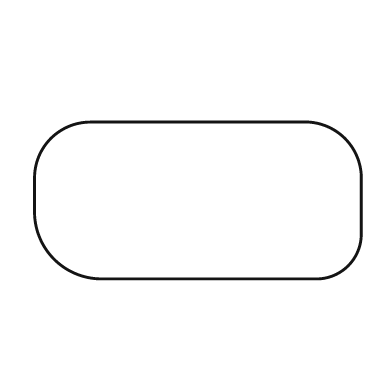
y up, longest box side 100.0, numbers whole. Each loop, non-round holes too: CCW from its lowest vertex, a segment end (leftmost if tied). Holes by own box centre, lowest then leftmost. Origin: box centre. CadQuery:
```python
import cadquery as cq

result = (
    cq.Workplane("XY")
    .moveTo(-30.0, -24.0)
    .lineTo(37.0, -24.0)
    .threePointArc((46.0, -20.0), (50.0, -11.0))
    .lineTo(50.0, 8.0)
    .threePointArc((45.0, 19.0), (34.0, 24.0))
    .lineTo(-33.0, 24.0)
    .threePointArc((-45.0, 19.0), (-50.0, 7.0))
    .lineTo(-50.0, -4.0)
    .threePointArc((-44.0, -18.0), (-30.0, -24.0))
    .close()
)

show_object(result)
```